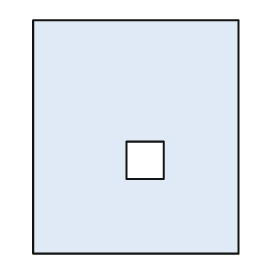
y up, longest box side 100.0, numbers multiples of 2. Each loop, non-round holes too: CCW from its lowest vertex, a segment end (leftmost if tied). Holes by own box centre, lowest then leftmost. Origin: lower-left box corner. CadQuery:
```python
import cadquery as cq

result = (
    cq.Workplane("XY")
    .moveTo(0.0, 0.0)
    .lineTo(88.0, 0.0)
    .lineTo(88.0, 100.0)
    .lineTo(0.0, 100.0)
    .close()
    .moveTo(40.0, 32.0)
    .lineTo(56.0, 32.0)
    .lineTo(56.0, 48.0)
    .lineTo(40.0, 48.0)
    .close()
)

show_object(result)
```